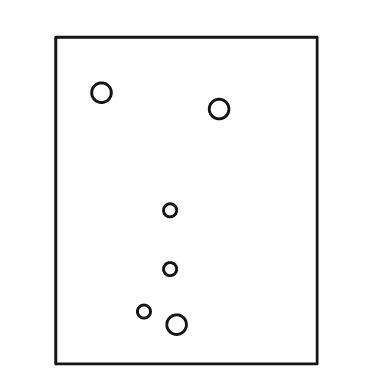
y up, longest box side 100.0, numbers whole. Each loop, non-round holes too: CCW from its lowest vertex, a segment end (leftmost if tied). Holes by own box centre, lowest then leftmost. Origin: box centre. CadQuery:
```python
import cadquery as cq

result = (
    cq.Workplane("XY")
    .moveTo(-40.0, -50.0)
    .lineTo(40.0, -50.0)
    .lineTo(40.0, 50.0)
    .lineTo(-40.0, 50.0)
    .close()
    .moveTo(-3.0, -38.0)
    .circle(3.0)
    .moveTo(-13.0, -34.0)
    .circle(2.0)
    .moveTo(-5.0, -21.0)
    .circle(2.0)
    .moveTo(-5.0, -3.0)
    .circle(2.0)
    .moveTo(10.0, 28.0)
    .circle(3.0)
    .moveTo(-26.0, 33.0)
    .circle(3.0)
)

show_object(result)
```